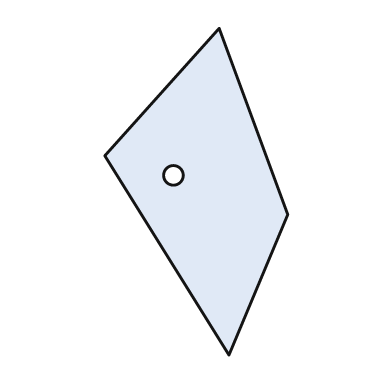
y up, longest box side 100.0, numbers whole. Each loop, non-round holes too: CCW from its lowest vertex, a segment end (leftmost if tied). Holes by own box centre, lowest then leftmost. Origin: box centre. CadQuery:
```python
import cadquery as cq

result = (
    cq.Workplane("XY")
    .moveTo(10.0, -50.0)
    .lineTo(28.0, -7.0)
    .lineTo(7.0, 50.0)
    .lineTo(-28.0, 11.0)
    .close()
    .moveTo(-7.0, 5.0)
    .circle(3.0)
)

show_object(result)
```